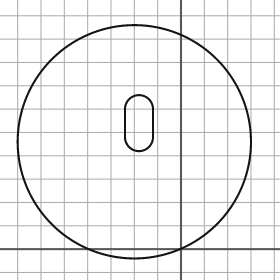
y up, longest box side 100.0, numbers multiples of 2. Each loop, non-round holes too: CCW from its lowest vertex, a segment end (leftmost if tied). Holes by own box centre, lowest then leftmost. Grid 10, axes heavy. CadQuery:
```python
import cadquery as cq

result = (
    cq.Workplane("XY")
    .moveTo(-20.0, 46.0)
    .circle(50.0)
    .moveTo(-24.0, 48.0)
    .threePointArc((-18.0, 42.0), (-12.0, 48.0))
    .lineTo(-12.0, 60.0)
    .threePointArc((-18.0, 66.0), (-24.0, 60.0))
    .close()
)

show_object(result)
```